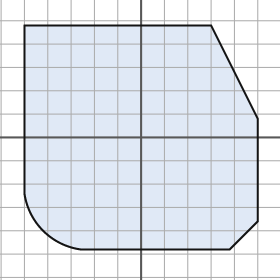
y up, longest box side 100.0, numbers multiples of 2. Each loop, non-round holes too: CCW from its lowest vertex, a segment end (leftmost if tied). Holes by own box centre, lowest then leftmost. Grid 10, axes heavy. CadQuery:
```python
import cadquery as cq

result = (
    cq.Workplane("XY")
    .moveTo(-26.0, -48.0)
    .lineTo(38.0, -48.0)
    .lineTo(50.0, -36.0)
    .lineTo(50.0, 8.0)
    .lineTo(30.0, 48.0)
    .lineTo(-50.0, 48.0)
    .lineTo(-50.0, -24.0)
    .threePointArc((-42.0, -40.0), (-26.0, -48.0))
    .close()
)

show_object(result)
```